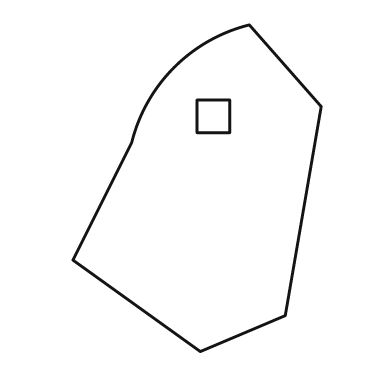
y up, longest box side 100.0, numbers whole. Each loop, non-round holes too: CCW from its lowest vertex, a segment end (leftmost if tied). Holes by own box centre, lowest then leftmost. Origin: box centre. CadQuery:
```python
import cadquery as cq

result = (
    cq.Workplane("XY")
    .moveTo(1.0, -50.0)
    .lineTo(27.0, -39.0)
    .lineTo(38.0, 25.0)
    .lineTo(16.0, 50.0)
    .threePointArc((-7.0, 37.0), (-20.0, 14.0))
    .lineTo(-38.0, -22.0)
    .close()
    .moveTo(0.0, 17.0)
    .lineTo(10.0, 17.0)
    .lineTo(10.0, 27.0)
    .lineTo(0.0, 27.0)
    .close()
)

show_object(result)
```